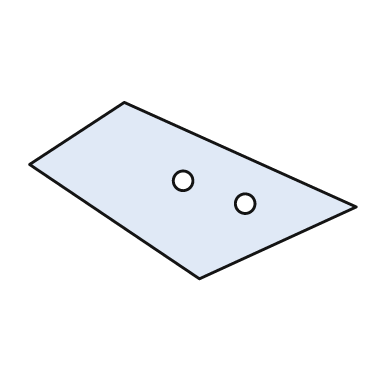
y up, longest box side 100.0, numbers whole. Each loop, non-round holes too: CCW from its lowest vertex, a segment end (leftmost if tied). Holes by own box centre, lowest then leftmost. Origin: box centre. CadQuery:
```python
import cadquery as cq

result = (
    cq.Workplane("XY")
    .moveTo(2.0, -27.0)
    .lineTo(50.0, -5.0)
    .lineTo(-21.0, 27.0)
    .lineTo(-50.0, 8.0)
    .close()
    .moveTo(16.0, -4.0)
    .circle(3.0)
    .moveTo(-3.0, 3.0)
    .circle(3.0)
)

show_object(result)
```